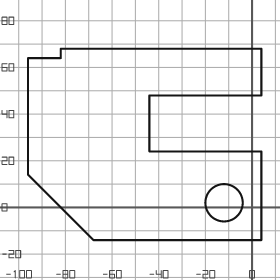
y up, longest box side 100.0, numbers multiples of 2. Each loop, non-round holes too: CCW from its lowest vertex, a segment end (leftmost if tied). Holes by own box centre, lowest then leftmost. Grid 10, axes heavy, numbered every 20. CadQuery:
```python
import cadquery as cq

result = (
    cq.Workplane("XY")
    .moveTo(-68.0, -14.0)
    .lineTo(4.0, -14.0)
    .lineTo(4.0, 24.0)
    .lineTo(-44.0, 24.0)
    .lineTo(-44.0, 48.0)
    .lineTo(4.0, 48.0)
    .lineTo(4.0, 68.0)
    .lineTo(-82.0, 68.0)
    .lineTo(-82.0, 64.0)
    .lineTo(-96.0, 64.0)
    .lineTo(-96.0, 14.0)
    .close()
    .moveTo(-12.0, 2.0)
    .circle(8.0)
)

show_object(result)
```